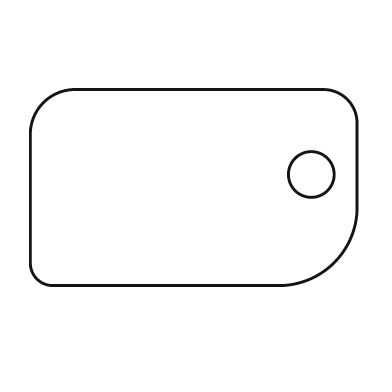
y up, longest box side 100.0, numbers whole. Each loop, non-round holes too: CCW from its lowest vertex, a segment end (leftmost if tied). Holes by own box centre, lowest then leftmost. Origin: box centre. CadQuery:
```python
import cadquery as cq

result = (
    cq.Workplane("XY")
    .moveTo(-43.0, -30.0)
    .lineTo(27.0, -30.0)
    .threePointArc((43.0, -23.0), (50.0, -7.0))
    .lineTo(50.0, 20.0)
    .threePointArc((47.0, 27.0), (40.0, 30.0))
    .lineTo(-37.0, 30.0)
    .threePointArc((-46.0, 26.0), (-50.0, 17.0))
    .lineTo(-50.0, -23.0)
    .threePointArc((-48.0, -28.0), (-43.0, -30.0))
    .close()
    .moveTo(36.0, 4.0)
    .circle(7.0)
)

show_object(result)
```